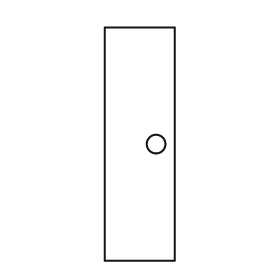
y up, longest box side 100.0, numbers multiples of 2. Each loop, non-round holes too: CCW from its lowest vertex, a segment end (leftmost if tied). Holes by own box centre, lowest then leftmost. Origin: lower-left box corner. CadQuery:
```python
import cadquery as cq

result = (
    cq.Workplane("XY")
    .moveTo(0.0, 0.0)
    .lineTo(30.0, 0.0)
    .lineTo(30.0, 100.0)
    .lineTo(0.0, 100.0)
    .close()
    .moveTo(22.0, 50.0)
    .circle(4.0)
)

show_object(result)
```